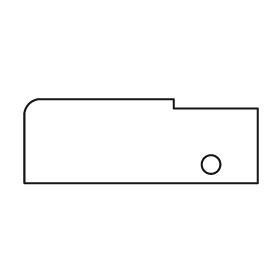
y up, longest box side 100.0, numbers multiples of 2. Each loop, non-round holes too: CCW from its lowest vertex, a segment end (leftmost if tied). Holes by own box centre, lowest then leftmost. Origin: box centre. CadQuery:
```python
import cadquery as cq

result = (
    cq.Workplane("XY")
    .moveTo(-50.0, -18.0)
    .lineTo(50.0, -18.0)
    .lineTo(50.0, 14.0)
    .lineTo(14.0, 14.0)
    .lineTo(14.0, 18.0)
    .lineTo(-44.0, 18.0)
    .threePointArc((-48.0, 16.0), (-50.0, 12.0))
    .close()
    .moveTo(30.0, -10.0)
    .circle(4.0)
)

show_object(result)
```